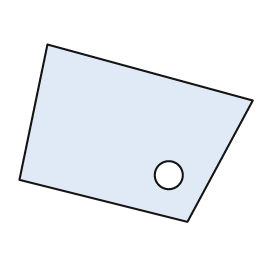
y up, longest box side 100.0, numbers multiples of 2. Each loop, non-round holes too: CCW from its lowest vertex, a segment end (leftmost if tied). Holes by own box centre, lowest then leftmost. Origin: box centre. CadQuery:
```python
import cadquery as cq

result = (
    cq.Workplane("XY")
    .moveTo(22.0, -38.0)
    .lineTo(50.0, 14.0)
    .lineTo(-38.0, 38.0)
    .lineTo(-50.0, -20.0)
    .close()
    .moveTo(14.0, -18.0)
    .circle(6.0)
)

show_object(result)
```